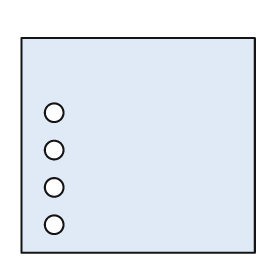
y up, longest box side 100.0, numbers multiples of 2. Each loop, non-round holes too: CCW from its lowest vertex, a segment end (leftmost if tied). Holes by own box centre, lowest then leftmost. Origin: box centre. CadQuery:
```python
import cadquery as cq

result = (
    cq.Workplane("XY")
    .moveTo(-50.0, -46.0)
    .lineTo(50.0, -46.0)
    .lineTo(50.0, 46.0)
    .lineTo(-50.0, 46.0)
    .close()
    .moveTo(-36.0, -34.0)
    .circle(4.0)
    .moveTo(-36.0, -18.0)
    .circle(4.0)
    .moveTo(-36.0, -2.0)
    .circle(4.0)
    .moveTo(-36.0, 14.0)
    .circle(4.0)
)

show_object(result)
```